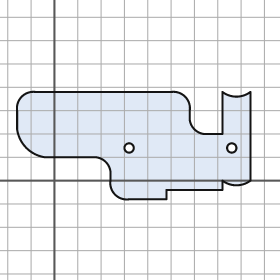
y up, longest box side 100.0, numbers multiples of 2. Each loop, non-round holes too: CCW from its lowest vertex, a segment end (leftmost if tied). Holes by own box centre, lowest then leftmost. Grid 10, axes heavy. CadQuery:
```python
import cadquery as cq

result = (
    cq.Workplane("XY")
    .moveTo(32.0, -8.0)
    .lineTo(48.0, -8.0)
    .lineTo(48.0, -4.0)
    .lineTo(72.0, -4.0)
    .lineTo(72.0, 0.0)
    .threePointArc((78.0, -2.0), (84.0, 0.0))
    .lineTo(84.0, 38.0)
    .threePointArc((78.0, 36.0), (72.0, 38.0))
    .lineTo(72.0, 20.0)
    .lineTo(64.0, 20.0)
    .threePointArc((60.0, 22.0), (58.0, 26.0))
    .lineTo(58.0, 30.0)
    .threePointArc((56.0, 36.0), (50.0, 38.0))
    .lineTo(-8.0, 38.0)
    .threePointArc((-14.0, 36.0), (-16.0, 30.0))
    .lineTo(-16.0, 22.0)
    .threePointArc((-12.0, 14.0), (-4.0, 10.0))
    .lineTo(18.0, 10.0)
    .threePointArc((22.0, 8.0), (24.0, 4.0))
    .lineTo(24.0, 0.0)
    .threePointArc((26.0, -6.0), (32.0, -8.0))
    .close()
    .moveTo(32.0, 14.0)
    .circle(2.0)
    .moveTo(76.0, 14.0)
    .circle(2.0)
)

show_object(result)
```